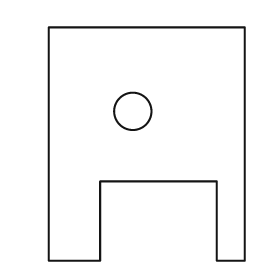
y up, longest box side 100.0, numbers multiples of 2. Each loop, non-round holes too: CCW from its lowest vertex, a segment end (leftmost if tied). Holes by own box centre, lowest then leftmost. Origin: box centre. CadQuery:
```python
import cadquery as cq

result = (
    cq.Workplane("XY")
    .moveTo(-42.0, -50.0)
    .lineTo(-20.0, -50.0)
    .lineTo(-20.0, -16.0)
    .lineTo(30.0, -16.0)
    .lineTo(30.0, -50.0)
    .lineTo(42.0, -50.0)
    .lineTo(42.0, 50.0)
    .lineTo(-42.0, 50.0)
    .close()
    .moveTo(-6.0, 14.0)
    .circle(8.0)
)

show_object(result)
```